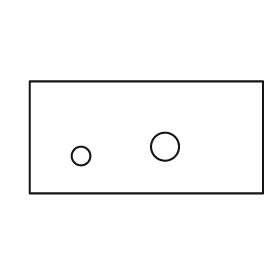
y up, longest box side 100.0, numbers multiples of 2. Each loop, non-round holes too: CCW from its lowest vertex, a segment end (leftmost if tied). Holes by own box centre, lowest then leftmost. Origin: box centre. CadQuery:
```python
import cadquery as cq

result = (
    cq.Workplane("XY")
    .moveTo(-50.0, -24.0)
    .lineTo(50.0, -24.0)
    .lineTo(50.0, 24.0)
    .lineTo(-50.0, 24.0)
    .close()
    .moveTo(-28.0, -8.0)
    .circle(4.0)
    .moveTo(8.0, -4.0)
    .circle(6.0)
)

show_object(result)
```